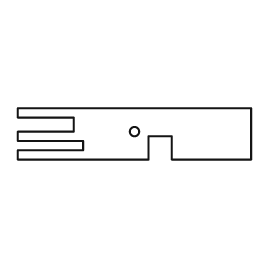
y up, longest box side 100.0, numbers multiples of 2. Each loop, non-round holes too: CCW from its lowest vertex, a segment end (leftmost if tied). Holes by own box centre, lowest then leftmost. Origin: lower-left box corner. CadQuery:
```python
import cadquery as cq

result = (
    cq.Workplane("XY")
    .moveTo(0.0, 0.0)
    .lineTo(56.0, 0.0)
    .lineTo(56.0, 10.0)
    .lineTo(66.0, 10.0)
    .lineTo(66.0, 0.0)
    .lineTo(100.0, 0.0)
    .lineTo(100.0, 22.0)
    .lineTo(0.0, 22.0)
    .lineTo(0.0, 18.0)
    .lineTo(24.0, 18.0)
    .lineTo(24.0, 12.0)
    .lineTo(0.0, 12.0)
    .lineTo(0.0, 8.0)
    .lineTo(28.0, 8.0)
    .lineTo(28.0, 4.0)
    .lineTo(0.0, 4.0)
    .close()
    .moveTo(50.0, 12.0)
    .circle(2.0)
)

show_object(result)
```